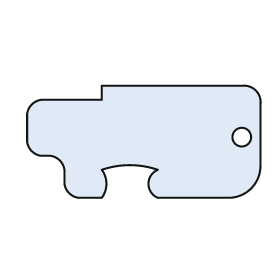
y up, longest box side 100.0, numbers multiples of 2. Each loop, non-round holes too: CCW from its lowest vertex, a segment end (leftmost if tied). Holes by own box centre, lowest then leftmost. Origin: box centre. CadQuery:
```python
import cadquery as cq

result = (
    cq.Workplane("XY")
    .moveTo(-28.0, -24.0)
    .lineTo(-18.0, -24.0)
    .threePointArc((-16.0, -18.0), (-18.0, -12.0))
    .threePointArc((-6.0, -10.0), (6.0, -12.0))
    .threePointArc((2.0, -18.0), (6.0, -24.0))
    .lineTo(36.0, -24.0)
    .threePointArc((46.0, -20.0), (50.0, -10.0))
    .lineTo(50.0, 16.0)
    .threePointArc((48.0, 22.0), (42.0, 24.0))
    .lineTo(-18.0, 24.0)
    .lineTo(-18.0, 18.0)
    .lineTo(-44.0, 18.0)
    .threePointArc((-48.0, 16.0), (-50.0, 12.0))
    .lineTo(-50.0, 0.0)
    .threePointArc((-48.0, -4.0), (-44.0, -6.0))
    .lineTo(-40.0, -6.0)
    .threePointArc((-36.0, -8.0), (-34.0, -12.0))
    .lineTo(-34.0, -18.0)
    .threePointArc((-32.0, -22.0), (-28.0, -24.0))
    .close()
    .moveTo(42.0, 2.0)
    .circle(4.0)
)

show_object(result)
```